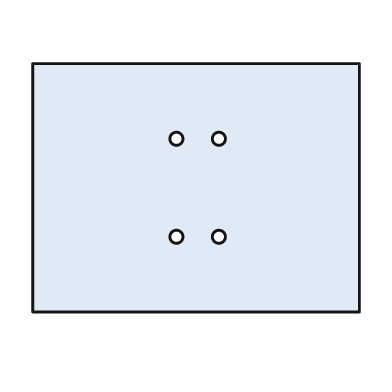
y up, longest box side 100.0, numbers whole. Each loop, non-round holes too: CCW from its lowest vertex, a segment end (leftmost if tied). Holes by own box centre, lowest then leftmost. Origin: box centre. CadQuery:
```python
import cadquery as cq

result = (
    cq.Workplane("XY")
    .moveTo(-50.0, -38.0)
    .lineTo(50.0, -38.0)
    .lineTo(50.0, 38.0)
    .lineTo(-50.0, 38.0)
    .close()
    .moveTo(-6.0, -15.0)
    .circle(2.0)
    .moveTo(7.0, -15.0)
    .circle(2.0)
    .moveTo(-6.0, 15.0)
    .circle(2.0)
    .moveTo(7.0, 15.0)
    .circle(2.0)
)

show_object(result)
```